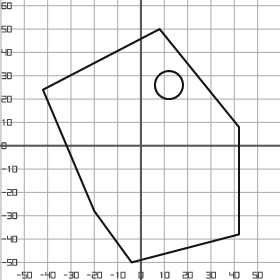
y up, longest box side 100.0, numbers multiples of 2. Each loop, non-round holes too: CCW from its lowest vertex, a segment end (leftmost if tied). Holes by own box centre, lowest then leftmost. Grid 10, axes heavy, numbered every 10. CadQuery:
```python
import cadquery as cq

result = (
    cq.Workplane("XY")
    .moveTo(-4.0, -50.0)
    .lineTo(42.0, -38.0)
    .lineTo(42.0, 8.0)
    .lineTo(8.0, 50.0)
    .lineTo(-42.0, 24.0)
    .lineTo(-20.0, -28.0)
    .close()
    .moveTo(12.0, 26.0)
    .circle(6.0)
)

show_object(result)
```